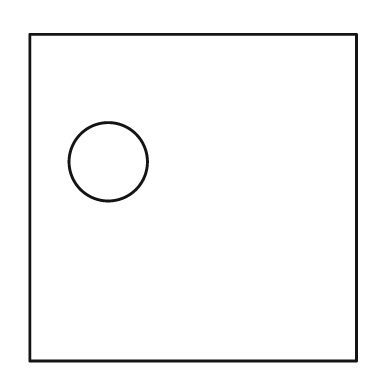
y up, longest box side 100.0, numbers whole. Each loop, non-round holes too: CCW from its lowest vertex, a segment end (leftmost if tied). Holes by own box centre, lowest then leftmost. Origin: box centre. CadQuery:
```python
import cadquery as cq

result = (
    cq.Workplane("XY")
    .moveTo(-50.0, -50.0)
    .lineTo(50.0, -50.0)
    .lineTo(50.0, 50.0)
    .lineTo(-50.0, 50.0)
    .close()
    .moveTo(-26.0, 11.0)
    .circle(12.0)
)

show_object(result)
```